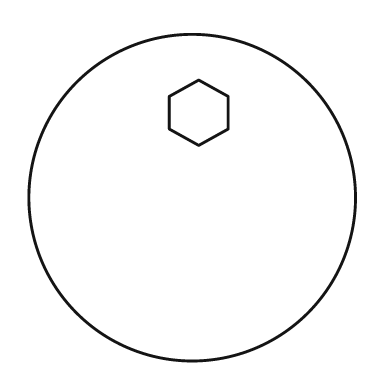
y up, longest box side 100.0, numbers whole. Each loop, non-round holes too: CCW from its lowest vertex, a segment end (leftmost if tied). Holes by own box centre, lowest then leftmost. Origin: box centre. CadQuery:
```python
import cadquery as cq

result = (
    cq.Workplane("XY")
    .moveTo(0.0, 0.0)
    .circle(50.0)
    .moveTo(2.0, 16.0)
    .lineTo(11.0, 21.0)
    .lineTo(11.0, 31.0)
    .lineTo(2.0, 36.0)
    .lineTo(-7.0, 31.0)
    .lineTo(-7.0, 21.0)
    .close()
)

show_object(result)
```